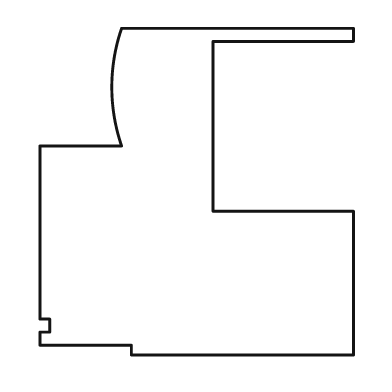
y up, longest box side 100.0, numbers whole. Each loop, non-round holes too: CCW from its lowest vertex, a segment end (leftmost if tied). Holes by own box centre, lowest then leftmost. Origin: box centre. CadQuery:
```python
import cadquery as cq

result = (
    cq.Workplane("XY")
    .moveTo(-20.0, -50.0)
    .lineTo(48.0, -50.0)
    .lineTo(48.0, -6.0)
    .lineTo(5.0, -6.0)
    .lineTo(5.0, 46.0)
    .lineTo(48.0, 46.0)
    .lineTo(48.0, 50.0)
    .lineTo(-23.0, 50.0)
    .threePointArc((-26.0, 32.0), (-23.0, 14.0))
    .lineTo(-48.0, 14.0)
    .lineTo(-48.0, -39.0)
    .lineTo(-45.0, -39.0)
    .lineTo(-45.0, -43.0)
    .lineTo(-48.0, -43.0)
    .lineTo(-48.0, -47.0)
    .lineTo(-20.0, -47.0)
    .close()
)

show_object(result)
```